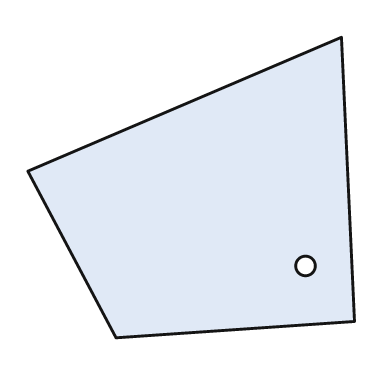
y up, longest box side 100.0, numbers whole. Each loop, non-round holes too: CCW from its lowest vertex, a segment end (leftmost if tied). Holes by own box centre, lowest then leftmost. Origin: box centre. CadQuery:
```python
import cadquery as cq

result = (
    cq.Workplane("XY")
    .moveTo(-23.0, -46.0)
    .lineTo(50.0, -41.0)
    .lineTo(46.0, 46.0)
    .lineTo(-50.0, 5.0)
    .close()
    .moveTo(35.0, -24.0)
    .circle(3.0)
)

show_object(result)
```